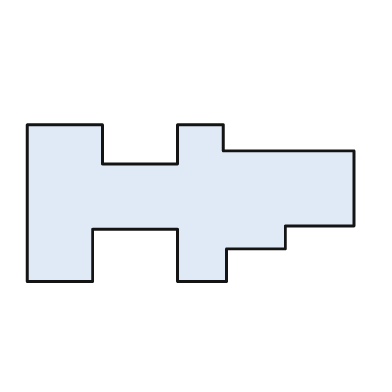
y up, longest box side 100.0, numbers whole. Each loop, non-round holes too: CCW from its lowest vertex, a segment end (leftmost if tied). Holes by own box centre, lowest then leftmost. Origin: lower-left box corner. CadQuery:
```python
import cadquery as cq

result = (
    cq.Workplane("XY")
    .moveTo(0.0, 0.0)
    .lineTo(20.0, 0.0)
    .lineTo(20.0, 16.0)
    .lineTo(46.0, 16.0)
    .lineTo(46.0, 0.0)
    .lineTo(61.0, 0.0)
    .lineTo(61.0, 10.0)
    .lineTo(79.0, 10.0)
    .lineTo(79.0, 17.0)
    .lineTo(100.0, 17.0)
    .lineTo(100.0, 40.0)
    .lineTo(60.0, 40.0)
    .lineTo(60.0, 48.0)
    .lineTo(46.0, 48.0)
    .lineTo(46.0, 36.0)
    .lineTo(23.0, 36.0)
    .lineTo(23.0, 48.0)
    .lineTo(0.0, 48.0)
    .close()
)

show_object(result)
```